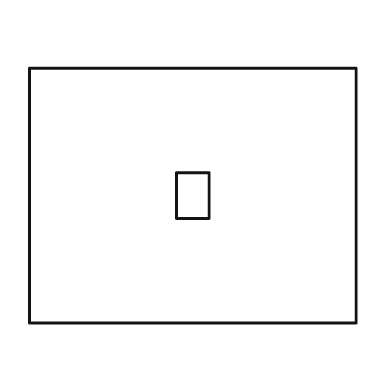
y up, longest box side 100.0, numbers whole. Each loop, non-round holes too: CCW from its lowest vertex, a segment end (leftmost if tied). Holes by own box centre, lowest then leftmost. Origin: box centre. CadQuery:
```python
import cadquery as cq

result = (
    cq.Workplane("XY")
    .moveTo(-50.0, -39.0)
    .lineTo(50.0, -39.0)
    .lineTo(50.0, 39.0)
    .lineTo(-50.0, 39.0)
    .close()
    .moveTo(-5.0, -7.0)
    .lineTo(5.0, -7.0)
    .lineTo(5.0, 7.0)
    .lineTo(-5.0, 7.0)
    .close()
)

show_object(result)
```